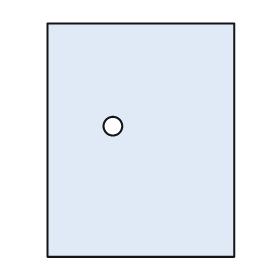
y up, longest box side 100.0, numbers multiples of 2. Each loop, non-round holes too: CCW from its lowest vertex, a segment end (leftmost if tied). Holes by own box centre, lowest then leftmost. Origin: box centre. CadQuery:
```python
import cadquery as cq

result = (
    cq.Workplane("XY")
    .moveTo(-40.0, -50.0)
    .lineTo(40.0, -50.0)
    .lineTo(40.0, 50.0)
    .lineTo(-40.0, 50.0)
    .close()
    .moveTo(-12.0, 6.0)
    .circle(4.0)
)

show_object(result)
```